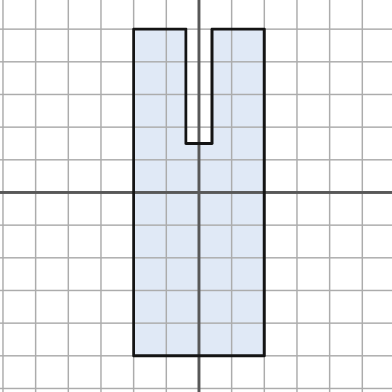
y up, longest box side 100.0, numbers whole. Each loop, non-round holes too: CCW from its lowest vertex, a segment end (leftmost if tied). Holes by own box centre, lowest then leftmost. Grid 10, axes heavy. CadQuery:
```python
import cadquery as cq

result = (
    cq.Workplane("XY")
    .moveTo(-20.0, -50.0)
    .lineTo(20.0, -50.0)
    .lineTo(20.0, 50.0)
    .lineTo(4.0, 50.0)
    .lineTo(4.0, 15.0)
    .lineTo(-4.0, 15.0)
    .lineTo(-4.0, 50.0)
    .lineTo(-20.0, 50.0)
    .close()
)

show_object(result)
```